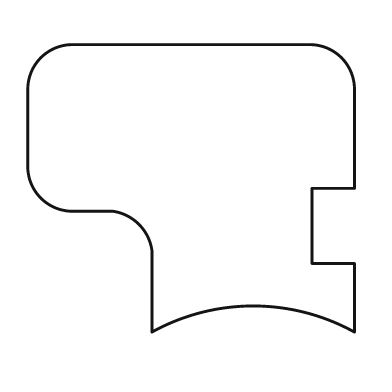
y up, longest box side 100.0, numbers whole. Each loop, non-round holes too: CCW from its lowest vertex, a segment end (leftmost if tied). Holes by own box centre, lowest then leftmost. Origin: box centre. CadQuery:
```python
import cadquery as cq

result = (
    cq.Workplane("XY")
    .moveTo(-12.0, -44.0)
    .threePointArc((19.0, -36.0), (50.0, -44.0))
    .lineTo(50.0, -23.0)
    .lineTo(37.0, -23.0)
    .lineTo(37.0, 0.0)
    .lineTo(50.0, 0.0)
    .lineTo(50.0, 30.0)
    .threePointArc((46.0, 40.0), (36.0, 44.0))
    .lineTo(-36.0, 44.0)
    .threePointArc((-46.0, 40.0), (-50.0, 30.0))
    .lineTo(-50.0, 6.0)
    .threePointArc((-46.0, -3.0), (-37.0, -7.0))
    .lineTo(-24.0, -7.0)
    .threePointArc((-16.0, -11.0), (-12.0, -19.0))
    .close()
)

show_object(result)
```